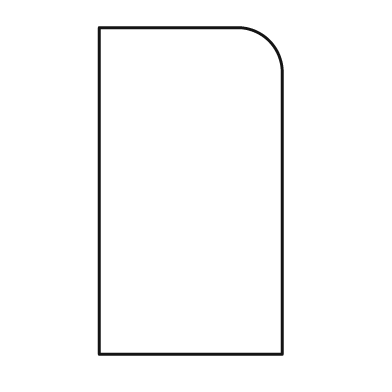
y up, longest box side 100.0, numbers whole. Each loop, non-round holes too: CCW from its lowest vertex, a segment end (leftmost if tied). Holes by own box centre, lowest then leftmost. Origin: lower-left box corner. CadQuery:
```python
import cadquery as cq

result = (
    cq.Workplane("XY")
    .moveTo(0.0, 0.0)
    .lineTo(56.0, 0.0)
    .lineTo(56.0, 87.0)
    .threePointArc((52.0, 96.0), (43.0, 100.0))
    .lineTo(0.0, 100.0)
    .close()
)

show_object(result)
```